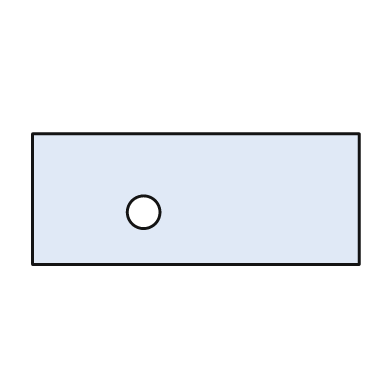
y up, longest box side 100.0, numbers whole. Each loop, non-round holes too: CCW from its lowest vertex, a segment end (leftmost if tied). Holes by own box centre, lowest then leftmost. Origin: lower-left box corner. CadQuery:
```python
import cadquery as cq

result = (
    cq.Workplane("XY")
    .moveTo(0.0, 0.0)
    .lineTo(100.0, 0.0)
    .lineTo(100.0, 40.0)
    .lineTo(0.0, 40.0)
    .close()
    .moveTo(34.0, 16.0)
    .circle(5.0)
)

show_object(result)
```